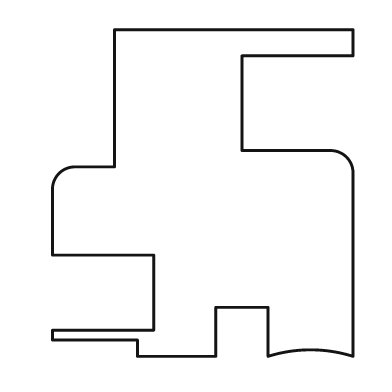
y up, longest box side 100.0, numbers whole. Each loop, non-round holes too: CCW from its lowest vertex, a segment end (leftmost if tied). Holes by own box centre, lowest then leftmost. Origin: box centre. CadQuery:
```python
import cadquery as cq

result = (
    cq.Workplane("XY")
    .moveTo(-20.0, -50.0)
    .lineTo(4.0, -50.0)
    .lineTo(4.0, -35.0)
    .lineTo(20.0, -35.0)
    .lineTo(20.0, -50.0)
    .threePointArc((33.0, -48.0), (46.0, -50.0))
    .lineTo(46.0, 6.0)
    .threePointArc((44.0, 11.0), (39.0, 13.0))
    .lineTo(12.0, 13.0)
    .lineTo(12.0, 42.0)
    .lineTo(46.0, 42.0)
    .lineTo(46.0, 50.0)
    .lineTo(-27.0, 50.0)
    .lineTo(-27.0, 8.0)
    .lineTo(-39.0, 8.0)
    .threePointArc((-44.0, 6.0), (-46.0, 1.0))
    .lineTo(-46.0, -19.0)
    .lineTo(-15.0, -19.0)
    .lineTo(-15.0, -42.0)
    .lineTo(-46.0, -42.0)
    .lineTo(-46.0, -45.0)
    .lineTo(-20.0, -45.0)
    .close()
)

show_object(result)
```